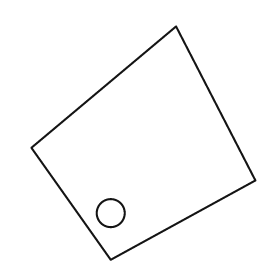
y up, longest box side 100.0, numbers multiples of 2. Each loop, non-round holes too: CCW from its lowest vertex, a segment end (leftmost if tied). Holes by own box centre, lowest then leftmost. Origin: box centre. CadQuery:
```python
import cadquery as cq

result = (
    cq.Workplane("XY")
    .moveTo(-14.0, -50.0)
    .lineTo(48.0, -16.0)
    .lineTo(14.0, 50.0)
    .lineTo(-48.0, -2.0)
    .close()
    .moveTo(-14.0, -30.0)
    .circle(6.0)
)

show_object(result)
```